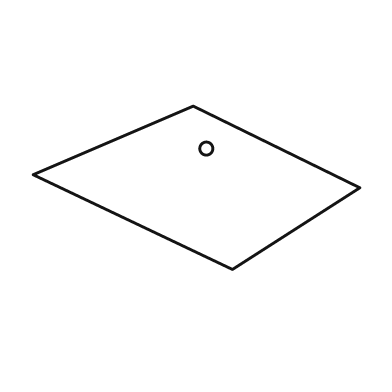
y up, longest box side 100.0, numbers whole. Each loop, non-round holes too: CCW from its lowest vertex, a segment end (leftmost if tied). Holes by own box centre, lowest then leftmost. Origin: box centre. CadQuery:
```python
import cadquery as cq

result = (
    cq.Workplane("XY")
    .moveTo(11.0, -25.0)
    .lineTo(50.0, 0.0)
    .lineTo(-1.0, 25.0)
    .lineTo(-50.0, 4.0)
    .close()
    .moveTo(3.0, 12.0)
    .circle(2.0)
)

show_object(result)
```